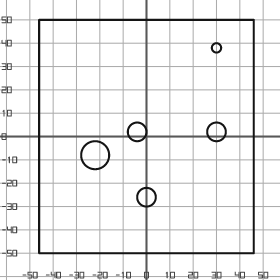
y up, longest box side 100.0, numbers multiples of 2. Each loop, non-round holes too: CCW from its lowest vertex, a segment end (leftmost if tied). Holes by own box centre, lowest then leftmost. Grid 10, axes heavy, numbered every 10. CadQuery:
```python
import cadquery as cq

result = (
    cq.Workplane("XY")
    .moveTo(-46.0, -50.0)
    .lineTo(46.0, -50.0)
    .lineTo(46.0, 50.0)
    .lineTo(-46.0, 50.0)
    .close()
    .moveTo(0.0, -26.0)
    .circle(4.0)
    .moveTo(-22.0, -8.0)
    .circle(6.0)
    .moveTo(-4.0, 2.0)
    .circle(4.0)
    .moveTo(30.0, 2.0)
    .circle(4.0)
    .moveTo(30.0, 38.0)
    .circle(2.0)
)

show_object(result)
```